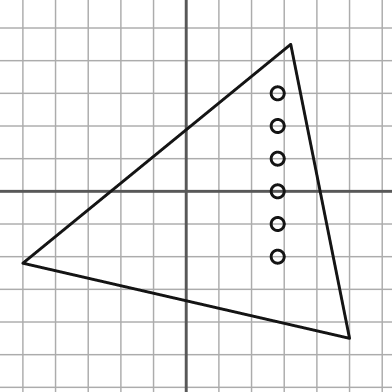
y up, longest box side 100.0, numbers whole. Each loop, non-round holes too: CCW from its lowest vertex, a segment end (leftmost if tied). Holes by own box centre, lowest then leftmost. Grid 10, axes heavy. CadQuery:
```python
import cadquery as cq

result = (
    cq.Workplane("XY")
    .moveTo(50.0, -45.0)
    .lineTo(32.0, 45.0)
    .lineTo(-50.0, -22.0)
    .close()
    .moveTo(28.0, -20.0)
    .circle(2.0)
    .moveTo(28.0, -10.0)
    .circle(2.0)
    .moveTo(28.0, 0.0)
    .circle(2.0)
    .moveTo(28.0, 10.0)
    .circle(2.0)
    .moveTo(28.0, 20.0)
    .circle(2.0)
    .moveTo(28.0, 30.0)
    .circle(2.0)
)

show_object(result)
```